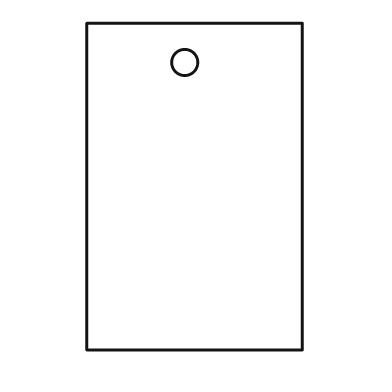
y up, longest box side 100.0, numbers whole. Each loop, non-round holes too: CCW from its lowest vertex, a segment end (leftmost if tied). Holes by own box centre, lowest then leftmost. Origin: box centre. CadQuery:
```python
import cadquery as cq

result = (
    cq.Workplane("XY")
    .moveTo(-33.0, -50.0)
    .lineTo(33.0, -50.0)
    .lineTo(33.0, 50.0)
    .lineTo(-33.0, 50.0)
    .close()
    .moveTo(-3.0, 38.0)
    .circle(4.0)
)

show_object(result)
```